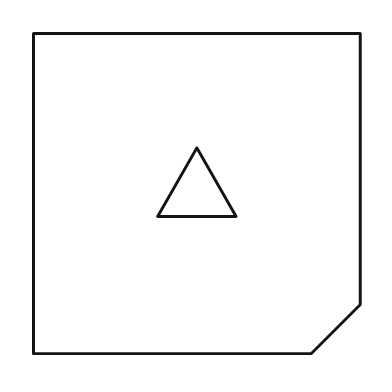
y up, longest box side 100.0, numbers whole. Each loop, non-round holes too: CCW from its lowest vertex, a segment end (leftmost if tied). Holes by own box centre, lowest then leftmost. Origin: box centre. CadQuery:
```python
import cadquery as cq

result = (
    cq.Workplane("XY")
    .moveTo(-50.0, -49.0)
    .lineTo(35.0, -49.0)
    .lineTo(50.0, -34.0)
    .lineTo(50.0, 49.0)
    .lineTo(-50.0, 49.0)
    .close()
    .moveTo(-12.0, -7.0)
    .lineTo(12.0, -7.0)
    .lineTo(0.0, 14.0)
    .close()
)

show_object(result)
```